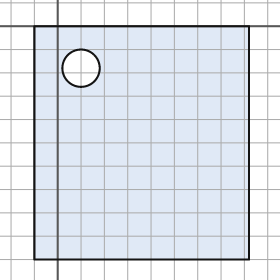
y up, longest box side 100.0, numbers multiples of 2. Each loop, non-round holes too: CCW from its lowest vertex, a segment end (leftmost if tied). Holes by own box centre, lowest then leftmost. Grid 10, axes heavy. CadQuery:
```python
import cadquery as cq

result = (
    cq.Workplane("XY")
    .moveTo(-10.0, -100.0)
    .lineTo(82.0, -100.0)
    .lineTo(82.0, 0.0)
    .lineTo(-10.0, 0.0)
    .close()
    .moveTo(10.0, -18.0)
    .circle(8.0)
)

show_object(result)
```